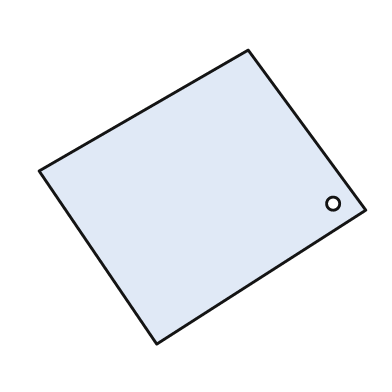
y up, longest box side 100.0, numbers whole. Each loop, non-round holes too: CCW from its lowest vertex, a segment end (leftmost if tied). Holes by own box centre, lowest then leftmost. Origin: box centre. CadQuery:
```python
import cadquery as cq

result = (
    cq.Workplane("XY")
    .moveTo(-14.0, -45.0)
    .lineTo(50.0, -4.0)
    .lineTo(14.0, 45.0)
    .lineTo(-50.0, 8.0)
    .close()
    .moveTo(40.0, -2.0)
    .circle(2.0)
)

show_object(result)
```